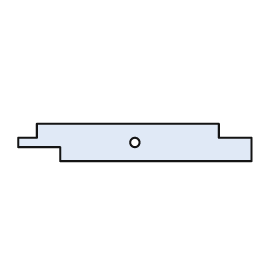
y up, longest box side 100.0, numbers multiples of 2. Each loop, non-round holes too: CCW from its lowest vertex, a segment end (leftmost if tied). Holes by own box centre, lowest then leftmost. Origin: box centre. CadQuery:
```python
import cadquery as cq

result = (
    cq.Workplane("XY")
    .moveTo(-32.0, -8.0)
    .lineTo(50.0, -8.0)
    .lineTo(50.0, 2.0)
    .lineTo(36.0, 2.0)
    .lineTo(36.0, 8.0)
    .lineTo(-42.0, 8.0)
    .lineTo(-42.0, 2.0)
    .lineTo(-50.0, 2.0)
    .lineTo(-50.0, -2.0)
    .lineTo(-32.0, -2.0)
    .close()
    .moveTo(0.0, 0.0)
    .circle(2.0)
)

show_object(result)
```